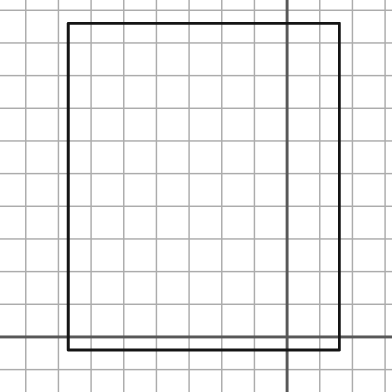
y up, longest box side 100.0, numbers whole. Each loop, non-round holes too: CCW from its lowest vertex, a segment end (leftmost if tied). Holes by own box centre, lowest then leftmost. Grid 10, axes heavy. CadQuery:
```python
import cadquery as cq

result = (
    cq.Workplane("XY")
    .moveTo(-67.0, -4.0)
    .lineTo(16.0, -4.0)
    .lineTo(16.0, 96.0)
    .lineTo(-67.0, 96.0)
    .close()
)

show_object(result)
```